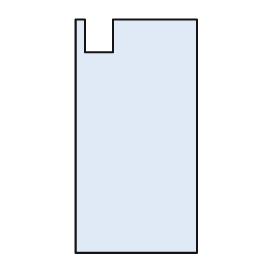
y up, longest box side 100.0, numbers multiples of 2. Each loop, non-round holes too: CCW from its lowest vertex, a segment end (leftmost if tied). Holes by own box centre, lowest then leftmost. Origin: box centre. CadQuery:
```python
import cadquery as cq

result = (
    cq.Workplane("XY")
    .moveTo(-26.0, -50.0)
    .lineTo(26.0, -50.0)
    .lineTo(26.0, 50.0)
    .lineTo(-10.0, 50.0)
    .lineTo(-10.0, 36.0)
    .lineTo(-22.0, 36.0)
    .lineTo(-22.0, 50.0)
    .lineTo(-26.0, 50.0)
    .close()
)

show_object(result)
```